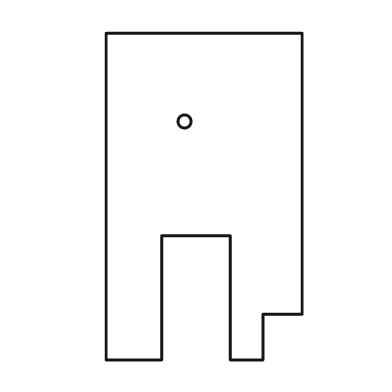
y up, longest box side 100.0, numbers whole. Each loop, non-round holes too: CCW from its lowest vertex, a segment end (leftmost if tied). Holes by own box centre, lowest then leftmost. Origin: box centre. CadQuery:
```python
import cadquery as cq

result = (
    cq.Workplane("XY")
    .moveTo(-30.0, -50.0)
    .lineTo(-13.0, -50.0)
    .lineTo(-13.0, -12.0)
    .lineTo(8.0, -12.0)
    .lineTo(8.0, -50.0)
    .lineTo(18.0, -50.0)
    .lineTo(18.0, -36.0)
    .lineTo(30.0, -36.0)
    .lineTo(30.0, 50.0)
    .lineTo(-30.0, 50.0)
    .close()
    .moveTo(-6.0, 23.0)
    .circle(2.0)
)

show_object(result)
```